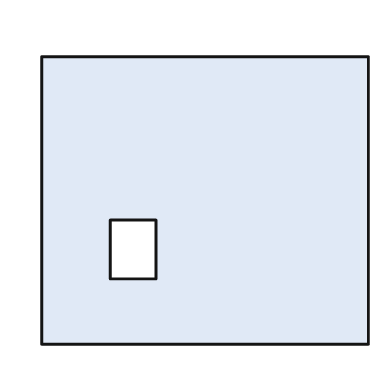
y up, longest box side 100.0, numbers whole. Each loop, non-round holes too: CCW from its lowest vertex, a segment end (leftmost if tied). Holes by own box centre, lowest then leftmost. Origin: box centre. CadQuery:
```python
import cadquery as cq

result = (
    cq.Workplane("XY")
    .moveTo(-50.0, -44.0)
    .lineTo(50.0, -44.0)
    .lineTo(50.0, 44.0)
    .lineTo(-50.0, 44.0)
    .close()
    .moveTo(-29.0, -24.0)
    .lineTo(-15.0, -24.0)
    .lineTo(-15.0, -6.0)
    .lineTo(-29.0, -6.0)
    .close()
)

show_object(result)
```